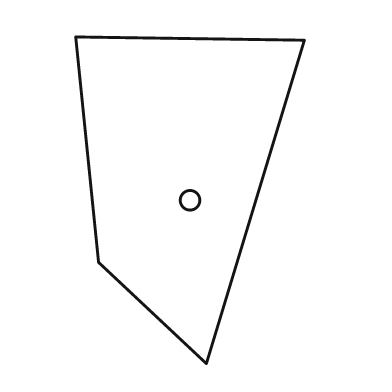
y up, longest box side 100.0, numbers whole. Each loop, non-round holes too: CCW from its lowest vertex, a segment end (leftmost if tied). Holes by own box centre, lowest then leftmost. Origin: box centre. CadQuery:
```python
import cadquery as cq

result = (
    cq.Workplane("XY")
    .moveTo(5.0, -50.0)
    .lineTo(35.0, 49.0)
    .lineTo(-35.0, 50.0)
    .lineTo(-28.0, -19.0)
    .close()
    .moveTo(0.0, 0.0)
    .circle(3.0)
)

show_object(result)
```